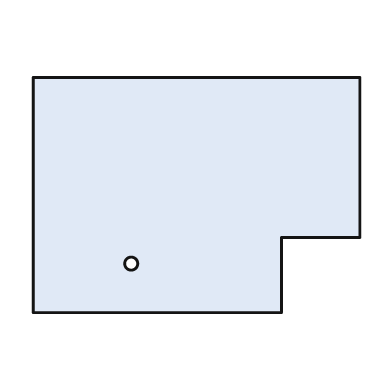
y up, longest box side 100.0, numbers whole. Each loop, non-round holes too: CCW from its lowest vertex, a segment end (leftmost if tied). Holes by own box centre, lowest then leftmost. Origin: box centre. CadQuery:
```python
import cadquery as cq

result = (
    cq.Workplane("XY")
    .moveTo(-50.0, -36.0)
    .lineTo(26.0, -36.0)
    .lineTo(26.0, -13.0)
    .lineTo(50.0, -13.0)
    .lineTo(50.0, 36.0)
    .lineTo(-50.0, 36.0)
    .close()
    .moveTo(-20.0, -21.0)
    .circle(2.0)
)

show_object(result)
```